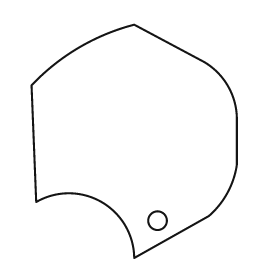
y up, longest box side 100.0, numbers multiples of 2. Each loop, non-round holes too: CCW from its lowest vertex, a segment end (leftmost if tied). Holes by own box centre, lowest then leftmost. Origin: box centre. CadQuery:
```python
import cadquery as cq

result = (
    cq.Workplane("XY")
    .moveTo(0.0, -50.0)
    .lineTo(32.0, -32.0)
    .threePointArc((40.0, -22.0), (44.0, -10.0))
    .lineTo(44.0, 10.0)
    .threePointArc((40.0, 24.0), (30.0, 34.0))
    .lineTo(0.0, 50.0)
    .threePointArc((-24.0, 40.0), (-44.0, 24.0))
    .lineTo(-42.0, -26.0)
    .threePointArc((-14.0, -26.0), (0.0, -50.0))
    .close()
    .moveTo(10.0, -34.0)
    .circle(4.0)
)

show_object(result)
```